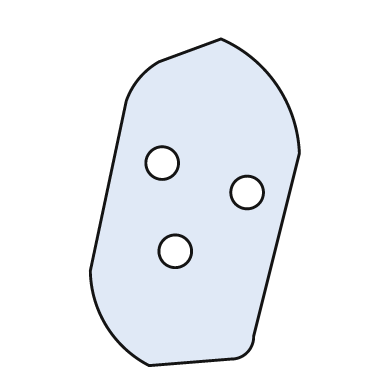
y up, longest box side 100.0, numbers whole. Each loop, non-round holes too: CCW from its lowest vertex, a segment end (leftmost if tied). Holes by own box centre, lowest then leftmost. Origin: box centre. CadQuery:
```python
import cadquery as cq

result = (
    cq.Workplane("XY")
    .moveTo(-14.0, -50.0)
    .lineTo(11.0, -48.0)
    .threePointArc((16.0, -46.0), (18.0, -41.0))
    .lineTo(32.0, 15.0)
    .threePointArc((25.0, 36.0), (8.0, 50.0))
    .lineTo(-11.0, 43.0)
    .threePointArc((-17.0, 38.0), (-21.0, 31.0))
    .lineTo(-32.0, -21.0)
    .threePointArc((-27.0, -38.0), (-14.0, -50.0))
    .close()
    .moveTo(-6.0, -15.0)
    .circle(5.0)
    .moveTo(16.0, 3.0)
    .circle(5.0)
    .moveTo(-10.0, 12.0)
    .circle(5.0)
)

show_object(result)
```